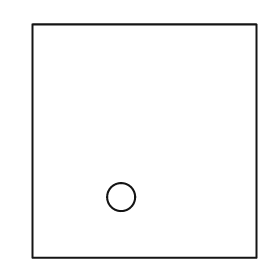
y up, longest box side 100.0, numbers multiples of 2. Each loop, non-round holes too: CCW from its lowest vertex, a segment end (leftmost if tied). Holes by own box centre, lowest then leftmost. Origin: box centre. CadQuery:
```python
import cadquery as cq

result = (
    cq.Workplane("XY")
    .moveTo(-48.0, -50.0)
    .lineTo(48.0, -50.0)
    .lineTo(48.0, 50.0)
    .lineTo(-48.0, 50.0)
    .close()
    .moveTo(-10.0, -24.0)
    .circle(6.0)
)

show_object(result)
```